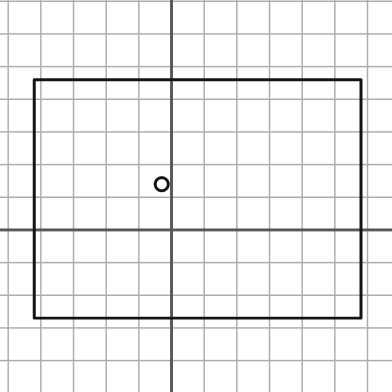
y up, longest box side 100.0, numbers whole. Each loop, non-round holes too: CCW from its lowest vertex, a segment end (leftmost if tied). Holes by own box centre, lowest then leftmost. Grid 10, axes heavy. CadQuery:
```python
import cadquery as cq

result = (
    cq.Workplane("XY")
    .moveTo(-42.0, -27.0)
    .lineTo(58.0, -27.0)
    .lineTo(58.0, 46.0)
    .lineTo(-42.0, 46.0)
    .close()
    .moveTo(-3.0, 14.0)
    .circle(2.0)
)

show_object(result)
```